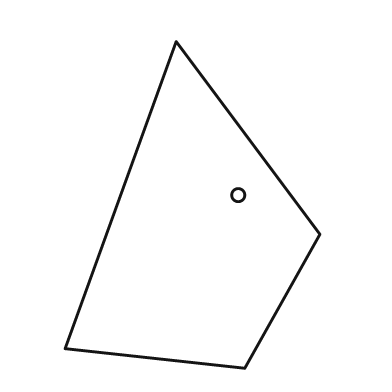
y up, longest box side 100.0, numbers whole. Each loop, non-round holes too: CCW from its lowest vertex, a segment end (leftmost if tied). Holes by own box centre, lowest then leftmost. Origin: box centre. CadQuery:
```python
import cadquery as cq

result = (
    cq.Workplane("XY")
    .moveTo(16.0, -50.0)
    .lineTo(39.0, -9.0)
    .lineTo(-5.0, 50.0)
    .lineTo(-39.0, -44.0)
    .close()
    .moveTo(14.0, 3.0)
    .circle(2.0)
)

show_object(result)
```